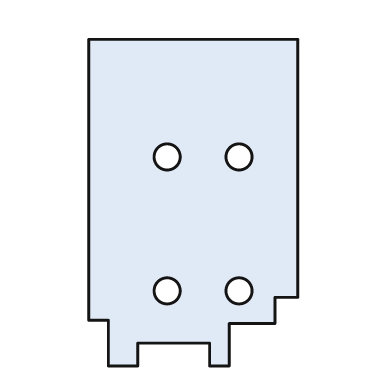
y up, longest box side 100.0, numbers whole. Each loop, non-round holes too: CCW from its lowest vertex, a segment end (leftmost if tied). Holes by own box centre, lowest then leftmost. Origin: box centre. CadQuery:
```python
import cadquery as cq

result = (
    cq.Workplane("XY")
    .moveTo(-26.0, -50.0)
    .lineTo(-17.0, -50.0)
    .lineTo(-17.0, -43.0)
    .lineTo(5.0, -43.0)
    .lineTo(5.0, -50.0)
    .lineTo(11.0, -50.0)
    .lineTo(11.0, -37.0)
    .lineTo(25.0, -37.0)
    .lineTo(25.0, -29.0)
    .lineTo(32.0, -29.0)
    .lineTo(32.0, 50.0)
    .lineTo(-32.0, 50.0)
    .lineTo(-32.0, -36.0)
    .lineTo(-26.0, -36.0)
    .close()
    .moveTo(-8.0, -27.0)
    .circle(4.0)
    .moveTo(14.0, -27.0)
    .circle(4.0)
    .moveTo(-8.0, 14.0)
    .circle(4.0)
    .moveTo(14.0, 14.0)
    .circle(4.0)
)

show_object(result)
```